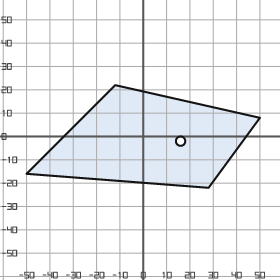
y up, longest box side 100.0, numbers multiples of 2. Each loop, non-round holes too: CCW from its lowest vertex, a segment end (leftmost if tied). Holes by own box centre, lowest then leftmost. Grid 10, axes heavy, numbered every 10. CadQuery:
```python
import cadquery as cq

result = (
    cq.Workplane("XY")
    .moveTo(28.0, -22.0)
    .lineTo(50.0, 8.0)
    .lineTo(-12.0, 22.0)
    .lineTo(-50.0, -16.0)
    .close()
    .moveTo(16.0, -2.0)
    .circle(2.0)
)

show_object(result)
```